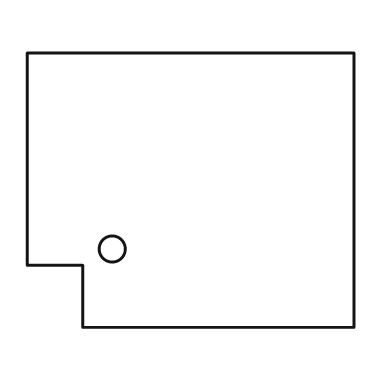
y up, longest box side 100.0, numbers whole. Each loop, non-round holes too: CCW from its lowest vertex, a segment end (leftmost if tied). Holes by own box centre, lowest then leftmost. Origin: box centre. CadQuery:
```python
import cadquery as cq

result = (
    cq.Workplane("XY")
    .moveTo(-33.0, -42.0)
    .lineTo(50.0, -42.0)
    .lineTo(50.0, 42.0)
    .lineTo(-50.0, 42.0)
    .lineTo(-50.0, -23.0)
    .lineTo(-33.0, -23.0)
    .close()
    .moveTo(-24.0, -18.0)
    .circle(4.0)
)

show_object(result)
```